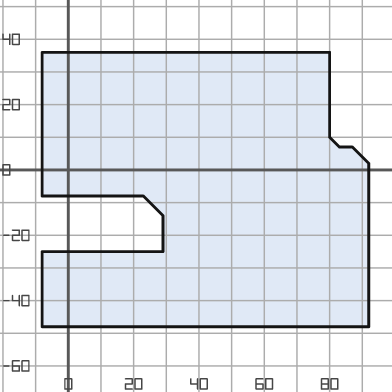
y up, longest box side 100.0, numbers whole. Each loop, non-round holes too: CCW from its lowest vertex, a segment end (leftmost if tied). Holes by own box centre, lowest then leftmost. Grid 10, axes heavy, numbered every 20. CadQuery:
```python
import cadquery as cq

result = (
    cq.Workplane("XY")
    .moveTo(-8.0, -48.0)
    .lineTo(92.0, -48.0)
    .lineTo(92.0, 2.0)
    .lineTo(87.0, 7.0)
    .lineTo(83.0, 7.0)
    .lineTo(80.0, 10.0)
    .lineTo(80.0, 36.0)
    .lineTo(-8.0, 36.0)
    .lineTo(-8.0, -8.0)
    .lineTo(23.0, -8.0)
    .lineTo(29.0, -14.0)
    .lineTo(29.0, -25.0)
    .lineTo(-8.0, -25.0)
    .close()
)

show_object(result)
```